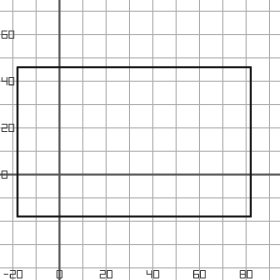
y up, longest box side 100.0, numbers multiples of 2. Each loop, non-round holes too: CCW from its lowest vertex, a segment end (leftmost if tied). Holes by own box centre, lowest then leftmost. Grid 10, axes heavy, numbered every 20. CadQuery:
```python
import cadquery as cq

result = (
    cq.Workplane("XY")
    .moveTo(-18.0, -18.0)
    .lineTo(82.0, -18.0)
    .lineTo(82.0, 46.0)
    .lineTo(-18.0, 46.0)
    .close()
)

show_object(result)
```